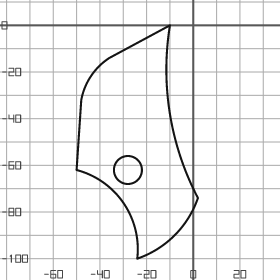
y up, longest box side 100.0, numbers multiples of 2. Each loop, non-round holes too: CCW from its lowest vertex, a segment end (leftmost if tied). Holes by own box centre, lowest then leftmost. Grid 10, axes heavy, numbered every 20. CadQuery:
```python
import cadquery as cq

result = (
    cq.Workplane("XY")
    .moveTo(-24.0, -100.0)
    .threePointArc((-8.0, -90.0), (2.0, -74.0))
    .threePointArc((-10.0, -38.0), (-10.0, 0.0))
    .lineTo(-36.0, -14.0)
    .threePointArc((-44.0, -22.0), (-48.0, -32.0))
    .lineTo(-50.0, -62.0)
    .threePointArc((-30.0, -76.0), (-24.0, -100.0))
    .close()
    .moveTo(-28.0, -62.0)
    .circle(6.0)
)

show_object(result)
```